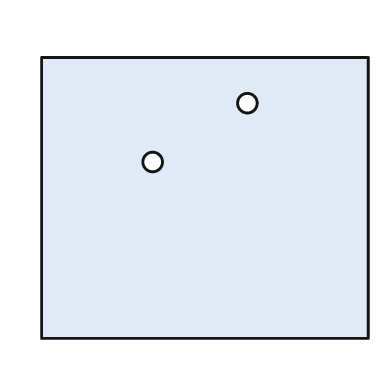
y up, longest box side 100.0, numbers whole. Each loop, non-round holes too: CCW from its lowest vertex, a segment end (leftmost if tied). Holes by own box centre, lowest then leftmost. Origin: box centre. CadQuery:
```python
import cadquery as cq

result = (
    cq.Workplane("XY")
    .moveTo(-50.0, -43.0)
    .lineTo(50.0, -43.0)
    .lineTo(50.0, 43.0)
    .lineTo(-50.0, 43.0)
    .close()
    .moveTo(-16.0, 11.0)
    .circle(3.0)
    .moveTo(13.0, 29.0)
    .circle(3.0)
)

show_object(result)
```